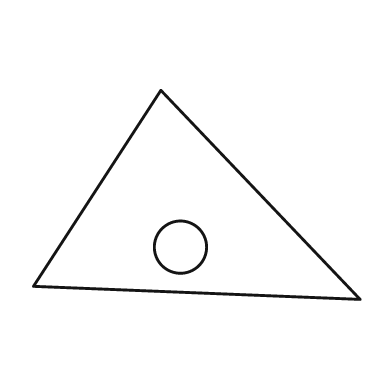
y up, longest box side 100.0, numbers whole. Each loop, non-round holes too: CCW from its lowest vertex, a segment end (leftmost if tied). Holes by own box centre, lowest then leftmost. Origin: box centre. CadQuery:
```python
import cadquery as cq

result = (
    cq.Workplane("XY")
    .moveTo(50.0, -32.0)
    .lineTo(-11.0, 32.0)
    .lineTo(-50.0, -28.0)
    .close()
    .moveTo(-5.0, -16.0)
    .circle(8.0)
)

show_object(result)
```